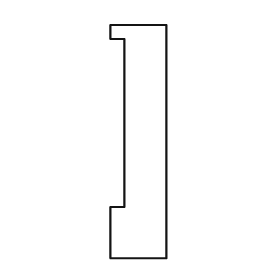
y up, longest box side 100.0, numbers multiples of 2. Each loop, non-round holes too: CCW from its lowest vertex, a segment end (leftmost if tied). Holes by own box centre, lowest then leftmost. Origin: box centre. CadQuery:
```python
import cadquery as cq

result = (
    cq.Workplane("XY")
    .moveTo(-12.0, -50.0)
    .lineTo(12.0, -50.0)
    .lineTo(12.0, 50.0)
    .lineTo(-12.0, 50.0)
    .lineTo(-12.0, 44.0)
    .lineTo(-6.0, 44.0)
    .lineTo(-6.0, -28.0)
    .lineTo(-12.0, -28.0)
    .close()
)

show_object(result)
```